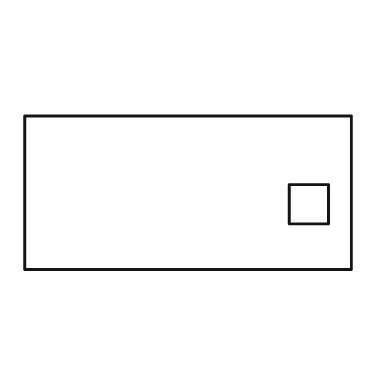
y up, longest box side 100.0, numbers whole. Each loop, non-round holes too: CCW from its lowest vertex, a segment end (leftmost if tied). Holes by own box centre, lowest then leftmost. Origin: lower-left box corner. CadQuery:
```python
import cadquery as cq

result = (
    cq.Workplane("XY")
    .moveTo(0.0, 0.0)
    .lineTo(100.0, 0.0)
    .lineTo(100.0, 47.0)
    .lineTo(0.0, 47.0)
    .close()
    .moveTo(81.0, 14.0)
    .lineTo(93.0, 14.0)
    .lineTo(93.0, 26.0)
    .lineTo(81.0, 26.0)
    .close()
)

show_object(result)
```